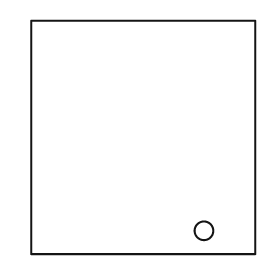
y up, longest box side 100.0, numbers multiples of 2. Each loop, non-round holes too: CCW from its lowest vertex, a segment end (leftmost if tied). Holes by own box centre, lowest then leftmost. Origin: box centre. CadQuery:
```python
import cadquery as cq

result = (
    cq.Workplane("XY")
    .moveTo(-48.0, -50.0)
    .lineTo(48.0, -50.0)
    .lineTo(48.0, 50.0)
    .lineTo(-48.0, 50.0)
    .close()
    .moveTo(26.0, -40.0)
    .circle(4.0)
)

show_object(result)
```